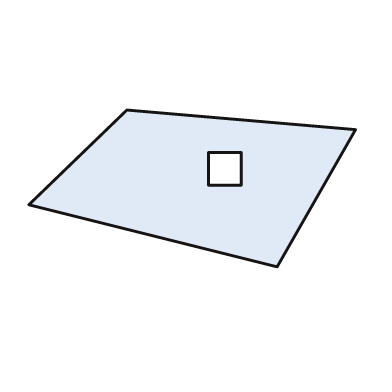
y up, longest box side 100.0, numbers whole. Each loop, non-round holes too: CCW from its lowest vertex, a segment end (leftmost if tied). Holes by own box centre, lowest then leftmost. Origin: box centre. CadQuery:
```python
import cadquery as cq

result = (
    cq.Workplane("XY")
    .moveTo(26.0, -24.0)
    .lineTo(50.0, 18.0)
    .lineTo(-20.0, 24.0)
    .lineTo(-50.0, -5.0)
    .close()
    .moveTo(5.0, 1.0)
    .lineTo(15.0, 1.0)
    .lineTo(15.0, 11.0)
    .lineTo(5.0, 11.0)
    .close()
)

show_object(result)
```